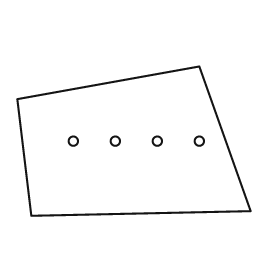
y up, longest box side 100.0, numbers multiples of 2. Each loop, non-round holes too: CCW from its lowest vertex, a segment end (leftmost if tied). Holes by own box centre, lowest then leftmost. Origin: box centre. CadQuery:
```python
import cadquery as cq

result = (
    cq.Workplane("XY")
    .moveTo(-44.0, -32.0)
    .lineTo(50.0, -30.0)
    .lineTo(28.0, 32.0)
    .lineTo(-50.0, 18.0)
    .close()
    .moveTo(-26.0, 0.0)
    .circle(2.0)
    .moveTo(-8.0, 0.0)
    .circle(2.0)
    .moveTo(10.0, 0.0)
    .circle(2.0)
    .moveTo(28.0, 0.0)
    .circle(2.0)
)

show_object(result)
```